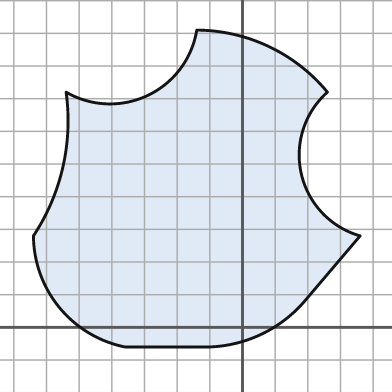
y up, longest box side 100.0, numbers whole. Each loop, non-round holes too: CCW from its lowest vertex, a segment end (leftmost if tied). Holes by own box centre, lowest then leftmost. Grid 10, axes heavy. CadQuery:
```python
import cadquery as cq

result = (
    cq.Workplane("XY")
    .moveTo(-36.0, -6.0)
    .lineTo(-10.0, -6.0)
    .threePointArc((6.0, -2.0), (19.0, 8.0))
    .lineTo(36.0, 28.0)
    .threePointArc((18.0, 47.0), (26.0, 72.0))
    .threePointArc((8.0, 86.0), (-14.0, 91.0))
    .threePointArc((-29.0, 71.0), (-54.0, 72.0))
    .threePointArc((-55.0, 49.0), (-64.0, 28.0))
    .threePointArc((-56.0, 6.0), (-36.0, -6.0))
    .close()
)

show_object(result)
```